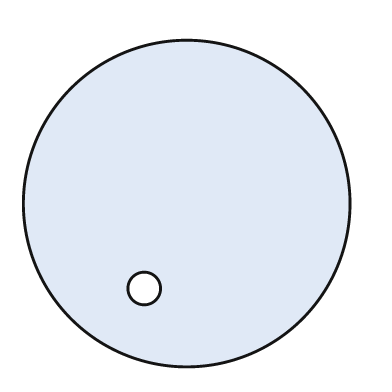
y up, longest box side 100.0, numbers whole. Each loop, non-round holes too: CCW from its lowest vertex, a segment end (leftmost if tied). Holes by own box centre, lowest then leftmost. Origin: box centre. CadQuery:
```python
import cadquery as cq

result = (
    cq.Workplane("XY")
    .moveTo(0.0, 0.0)
    .circle(50.0)
    .moveTo(-13.0, -26.0)
    .circle(5.0)
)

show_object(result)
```